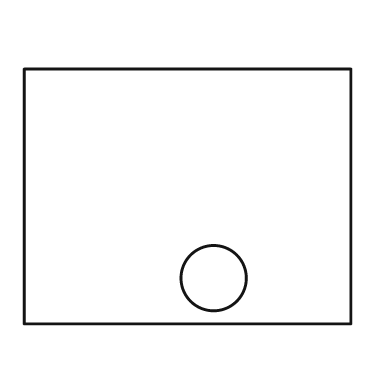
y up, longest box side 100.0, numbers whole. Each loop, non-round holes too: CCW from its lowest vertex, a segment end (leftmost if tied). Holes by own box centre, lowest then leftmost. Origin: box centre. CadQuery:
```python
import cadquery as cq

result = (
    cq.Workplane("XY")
    .moveTo(-50.0, -39.0)
    .lineTo(50.0, -39.0)
    .lineTo(50.0, 39.0)
    .lineTo(-50.0, 39.0)
    .close()
    .moveTo(8.0, -25.0)
    .circle(10.0)
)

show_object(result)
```